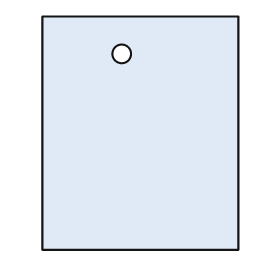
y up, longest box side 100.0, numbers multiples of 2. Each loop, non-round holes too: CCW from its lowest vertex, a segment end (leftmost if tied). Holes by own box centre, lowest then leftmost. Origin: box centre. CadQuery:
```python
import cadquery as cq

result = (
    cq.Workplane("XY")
    .moveTo(-42.0, -50.0)
    .lineTo(42.0, -50.0)
    .lineTo(42.0, 50.0)
    .lineTo(-42.0, 50.0)
    .close()
    .moveTo(-8.0, 34.0)
    .circle(4.0)
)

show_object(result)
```